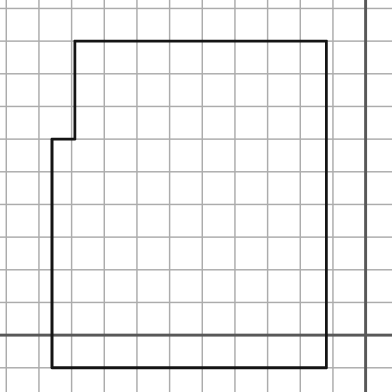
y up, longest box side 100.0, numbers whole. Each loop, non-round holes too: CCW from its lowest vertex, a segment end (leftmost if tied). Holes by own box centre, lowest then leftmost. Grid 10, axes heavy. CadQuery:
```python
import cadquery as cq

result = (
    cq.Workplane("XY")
    .moveTo(-96.0, -10.0)
    .lineTo(-12.0, -10.0)
    .lineTo(-12.0, 90.0)
    .lineTo(-89.0, 90.0)
    .lineTo(-89.0, 60.0)
    .lineTo(-96.0, 60.0)
    .close()
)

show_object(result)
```